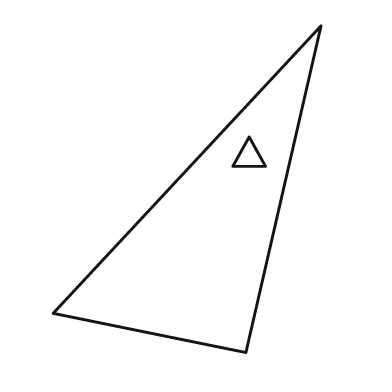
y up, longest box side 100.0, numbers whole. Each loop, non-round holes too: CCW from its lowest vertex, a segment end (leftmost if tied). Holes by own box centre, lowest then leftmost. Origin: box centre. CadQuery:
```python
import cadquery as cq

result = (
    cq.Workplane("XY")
    .moveTo(18.0, -50.0)
    .lineTo(41.0, 50.0)
    .lineTo(-41.0, -38.0)
    .close()
    .moveTo(14.0, 7.0)
    .lineTo(24.0, 7.0)
    .lineTo(19.0, 16.0)
    .close()
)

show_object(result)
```